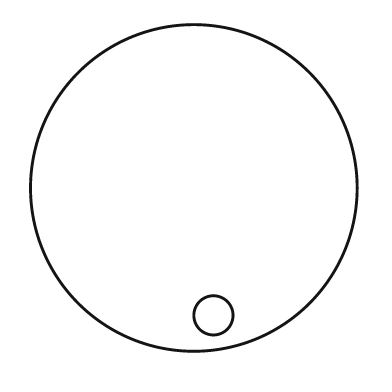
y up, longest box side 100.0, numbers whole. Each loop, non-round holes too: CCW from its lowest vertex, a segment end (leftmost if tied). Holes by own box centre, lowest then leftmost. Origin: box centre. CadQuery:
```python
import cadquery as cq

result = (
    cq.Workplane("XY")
    .moveTo(0.0, 0.0)
    .circle(50.0)
    .moveTo(6.0, -39.0)
    .circle(6.0)
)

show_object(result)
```